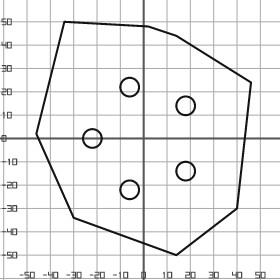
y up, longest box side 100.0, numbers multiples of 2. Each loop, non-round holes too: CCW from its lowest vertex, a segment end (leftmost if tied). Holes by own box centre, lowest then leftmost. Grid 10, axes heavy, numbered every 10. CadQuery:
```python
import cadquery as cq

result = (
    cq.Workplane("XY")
    .moveTo(14.0, -50.0)
    .lineTo(40.0, -30.0)
    .lineTo(46.0, 24.0)
    .lineTo(14.0, 44.0)
    .lineTo(2.0, 48.0)
    .lineTo(-34.0, 50.0)
    .lineTo(-46.0, 2.0)
    .lineTo(-30.0, -34.0)
    .close()
    .moveTo(-6.0, -22.0)
    .circle(4.0)
    .moveTo(18.0, -14.0)
    .circle(4.0)
    .moveTo(-22.0, 0.0)
    .circle(4.0)
    .moveTo(18.0, 14.0)
    .circle(4.0)
    .moveTo(-6.0, 22.0)
    .circle(4.0)
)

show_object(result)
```